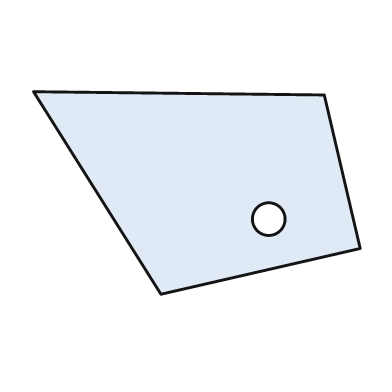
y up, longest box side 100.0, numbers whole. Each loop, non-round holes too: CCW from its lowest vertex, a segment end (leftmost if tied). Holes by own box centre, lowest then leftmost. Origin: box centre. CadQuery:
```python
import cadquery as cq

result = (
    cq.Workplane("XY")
    .moveTo(-11.0, -31.0)
    .lineTo(50.0, -17.0)
    .lineTo(39.0, 30.0)
    .lineTo(-50.0, 31.0)
    .close()
    .moveTo(22.0, -8.0)
    .circle(5.0)
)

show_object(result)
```